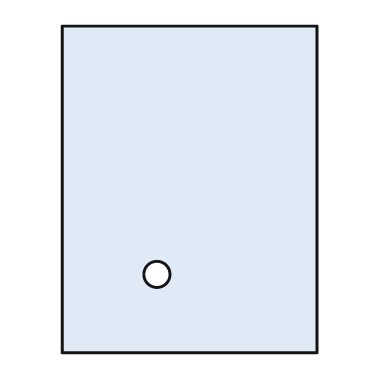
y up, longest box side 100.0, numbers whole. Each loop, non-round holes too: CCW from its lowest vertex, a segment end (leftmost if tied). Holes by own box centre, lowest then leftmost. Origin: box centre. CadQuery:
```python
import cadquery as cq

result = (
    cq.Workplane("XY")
    .moveTo(-39.0, -50.0)
    .lineTo(39.0, -50.0)
    .lineTo(39.0, 50.0)
    .lineTo(-39.0, 50.0)
    .close()
    .moveTo(-10.0, -26.0)
    .circle(4.0)
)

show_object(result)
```